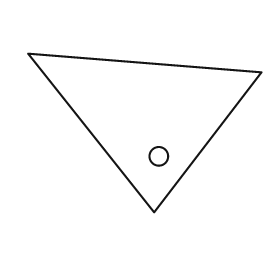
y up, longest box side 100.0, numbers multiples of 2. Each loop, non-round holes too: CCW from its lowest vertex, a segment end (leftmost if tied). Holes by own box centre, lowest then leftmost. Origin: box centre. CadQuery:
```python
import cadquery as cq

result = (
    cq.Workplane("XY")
    .moveTo(4.0, -34.0)
    .lineTo(50.0, 26.0)
    .lineTo(-50.0, 34.0)
    .close()
    .moveTo(6.0, -10.0)
    .circle(4.0)
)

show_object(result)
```